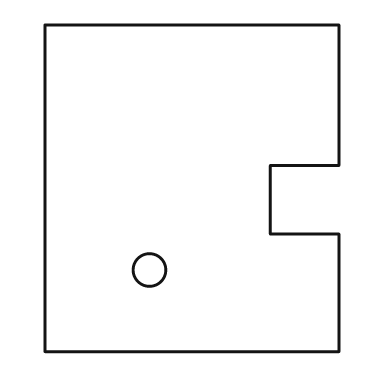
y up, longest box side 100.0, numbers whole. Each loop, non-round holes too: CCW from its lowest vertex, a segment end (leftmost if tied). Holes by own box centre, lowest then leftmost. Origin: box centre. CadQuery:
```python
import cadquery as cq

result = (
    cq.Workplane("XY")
    .moveTo(-45.0, -50.0)
    .lineTo(45.0, -50.0)
    .lineTo(45.0, -14.0)
    .lineTo(24.0, -14.0)
    .lineTo(24.0, 7.0)
    .lineTo(45.0, 7.0)
    .lineTo(45.0, 50.0)
    .lineTo(-45.0, 50.0)
    .close()
    .moveTo(-13.0, -25.0)
    .circle(5.0)
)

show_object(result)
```